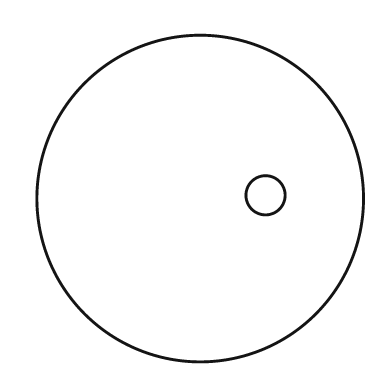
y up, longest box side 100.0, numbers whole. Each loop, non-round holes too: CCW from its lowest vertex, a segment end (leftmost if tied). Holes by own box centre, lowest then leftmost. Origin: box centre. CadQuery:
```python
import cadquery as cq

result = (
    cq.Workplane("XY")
    .moveTo(0.0, 0.0)
    .circle(50.0)
    .moveTo(20.0, 1.0)
    .circle(6.0)
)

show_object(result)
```